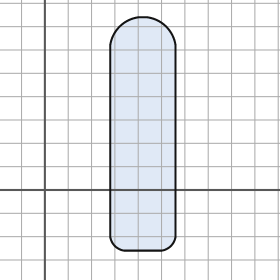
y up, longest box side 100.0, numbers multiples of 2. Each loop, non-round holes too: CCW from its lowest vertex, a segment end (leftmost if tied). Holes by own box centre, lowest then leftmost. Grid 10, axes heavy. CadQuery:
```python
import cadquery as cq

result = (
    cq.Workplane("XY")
    .moveTo(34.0, -26.0)
    .lineTo(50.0, -26.0)
    .threePointArc((54.0, -24.0), (56.0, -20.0))
    .lineTo(56.0, 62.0)
    .threePointArc((52.0, 70.0), (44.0, 74.0))
    .lineTo(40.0, 74.0)
    .threePointArc((32.0, 70.0), (28.0, 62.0))
    .lineTo(28.0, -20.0)
    .threePointArc((30.0, -24.0), (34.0, -26.0))
    .close()
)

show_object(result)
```